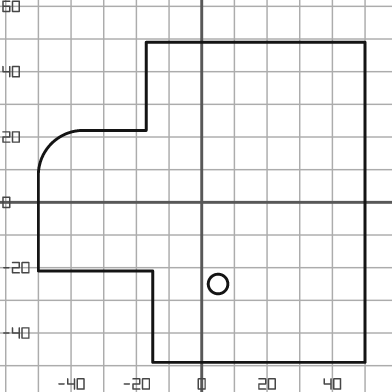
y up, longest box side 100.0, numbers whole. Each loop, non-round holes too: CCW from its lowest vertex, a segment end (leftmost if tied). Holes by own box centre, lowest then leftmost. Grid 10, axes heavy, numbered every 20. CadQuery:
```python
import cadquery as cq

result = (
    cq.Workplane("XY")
    .moveTo(-15.0, -49.0)
    .lineTo(50.0, -49.0)
    .lineTo(50.0, 49.0)
    .lineTo(-17.0, 49.0)
    .lineTo(-17.0, 22.0)
    .lineTo(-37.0, 22.0)
    .threePointArc((-46.0, 18.0), (-50.0, 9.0))
    .lineTo(-50.0, -21.0)
    .lineTo(-15.0, -21.0)
    .close()
    .moveTo(5.0, -25.0)
    .circle(3.0)
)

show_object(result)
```